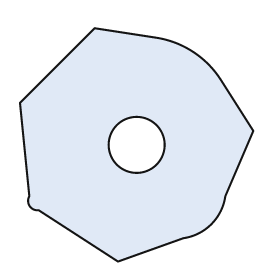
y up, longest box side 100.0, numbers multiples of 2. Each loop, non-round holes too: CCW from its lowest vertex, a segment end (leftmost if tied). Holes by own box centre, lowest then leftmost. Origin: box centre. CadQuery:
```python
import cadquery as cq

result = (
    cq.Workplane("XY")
    .moveTo(-8.0, -50.0)
    .lineTo(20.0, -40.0)
    .threePointArc((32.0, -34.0), (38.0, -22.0))
    .lineTo(50.0, 6.0)
    .lineTo(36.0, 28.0)
    .threePointArc((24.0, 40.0), (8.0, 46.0))
    .lineTo(-18.0, 50.0)
    .lineTo(-50.0, 18.0)
    .lineTo(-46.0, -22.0)
    .threePointArc((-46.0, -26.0), (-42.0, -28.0))
    .close()
    .moveTo(0.0, 0.0)
    .circle(12.0)
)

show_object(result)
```